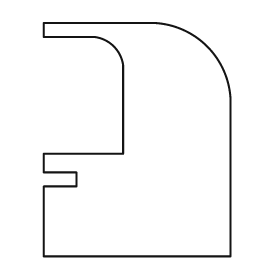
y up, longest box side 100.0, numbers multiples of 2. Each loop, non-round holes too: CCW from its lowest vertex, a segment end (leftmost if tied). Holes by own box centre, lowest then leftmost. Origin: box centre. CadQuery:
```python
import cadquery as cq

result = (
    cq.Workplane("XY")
    .moveTo(-40.0, -50.0)
    .lineTo(40.0, -50.0)
    .lineTo(40.0, 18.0)
    .threePointArc((30.0, 40.0), (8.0, 50.0))
    .lineTo(-40.0, 50.0)
    .lineTo(-40.0, 44.0)
    .lineTo(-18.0, 44.0)
    .threePointArc((-10.0, 40.0), (-6.0, 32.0))
    .lineTo(-6.0, -6.0)
    .lineTo(-40.0, -6.0)
    .lineTo(-40.0, -14.0)
    .lineTo(-26.0, -14.0)
    .lineTo(-26.0, -20.0)
    .lineTo(-40.0, -20.0)
    .close()
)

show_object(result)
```